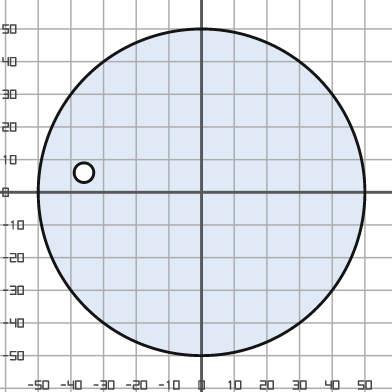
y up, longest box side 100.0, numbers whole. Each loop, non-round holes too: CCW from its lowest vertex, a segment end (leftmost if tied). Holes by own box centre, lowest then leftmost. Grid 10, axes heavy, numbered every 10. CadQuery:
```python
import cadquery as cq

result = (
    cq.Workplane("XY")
    .moveTo(0.0, 0.0)
    .circle(50.0)
    .moveTo(-36.0, 6.0)
    .circle(3.0)
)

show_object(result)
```